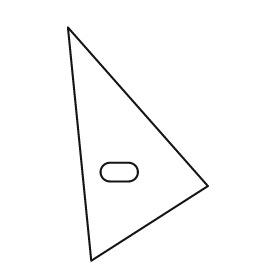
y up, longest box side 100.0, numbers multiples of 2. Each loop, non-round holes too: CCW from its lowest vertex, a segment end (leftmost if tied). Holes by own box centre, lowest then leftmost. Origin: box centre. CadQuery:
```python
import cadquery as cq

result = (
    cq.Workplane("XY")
    .moveTo(-20.0, -50.0)
    .lineTo(30.0, -18.0)
    .lineTo(-30.0, 50.0)
    .close()
    .moveTo(-12.0, -16.0)
    .lineTo(-4.0, -16.0)
    .threePointArc((0.0, -12.0), (-4.0, -8.0))
    .lineTo(-12.0, -8.0)
    .threePointArc((-16.0, -12.0), (-12.0, -16.0))
    .close()
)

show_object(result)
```